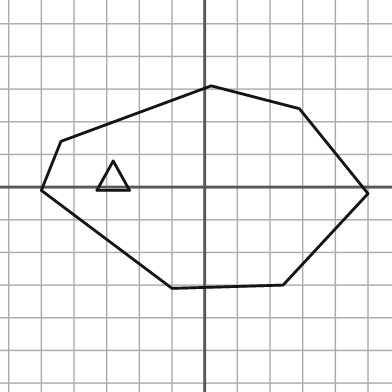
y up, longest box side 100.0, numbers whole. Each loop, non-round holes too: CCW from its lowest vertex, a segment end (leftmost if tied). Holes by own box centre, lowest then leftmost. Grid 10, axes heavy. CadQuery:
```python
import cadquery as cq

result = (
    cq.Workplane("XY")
    .moveTo(-10.0, -31.0)
    .lineTo(24.0, -30.0)
    .lineTo(50.0, -2.0)
    .lineTo(29.0, 24.0)
    .lineTo(2.0, 31.0)
    .lineTo(-44.0, 14.0)
    .lineTo(-50.0, -1.0)
    .close()
    .moveTo(-33.0, -1.0)
    .lineTo(-23.0, -1.0)
    .lineTo(-28.0, 8.0)
    .close()
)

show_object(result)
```